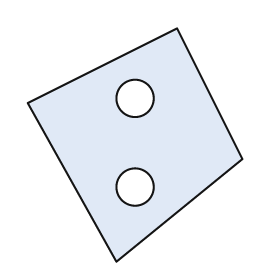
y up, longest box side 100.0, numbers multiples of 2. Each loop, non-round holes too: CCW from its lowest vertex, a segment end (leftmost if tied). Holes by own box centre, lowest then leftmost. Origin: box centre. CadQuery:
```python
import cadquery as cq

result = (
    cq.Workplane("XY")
    .moveTo(-8.0, -50.0)
    .lineTo(46.0, -6.0)
    .lineTo(18.0, 50.0)
    .lineTo(-46.0, 18.0)
    .close()
    .moveTo(0.0, -18.0)
    .circle(8.0)
    .moveTo(0.0, 20.0)
    .circle(8.0)
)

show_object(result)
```